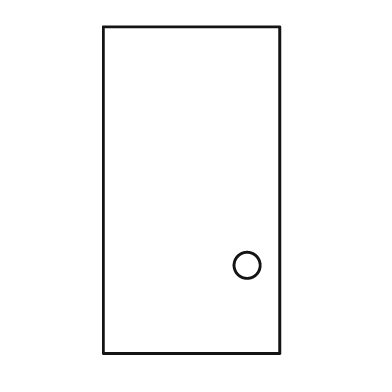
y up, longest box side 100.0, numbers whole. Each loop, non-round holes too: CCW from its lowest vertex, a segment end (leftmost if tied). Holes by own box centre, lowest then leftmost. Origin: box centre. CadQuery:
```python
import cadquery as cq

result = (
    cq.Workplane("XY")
    .moveTo(-27.0, -50.0)
    .lineTo(27.0, -50.0)
    .lineTo(27.0, 50.0)
    .lineTo(-27.0, 50.0)
    .close()
    .moveTo(17.0, -23.0)
    .circle(4.0)
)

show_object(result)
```